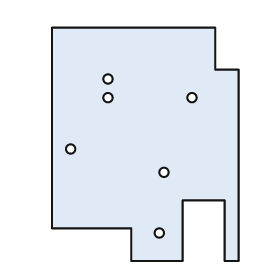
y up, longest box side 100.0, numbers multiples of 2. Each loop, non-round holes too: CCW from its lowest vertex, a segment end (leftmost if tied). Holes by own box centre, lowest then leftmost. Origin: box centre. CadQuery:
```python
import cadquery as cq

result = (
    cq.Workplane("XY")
    .moveTo(-6.0, -50.0)
    .lineTo(16.0, -50.0)
    .lineTo(16.0, -24.0)
    .lineTo(34.0, -24.0)
    .lineTo(34.0, -50.0)
    .lineTo(40.0, -50.0)
    .lineTo(40.0, 32.0)
    .lineTo(30.0, 32.0)
    .lineTo(30.0, 50.0)
    .lineTo(-40.0, 50.0)
    .lineTo(-40.0, -36.0)
    .lineTo(-6.0, -36.0)
    .close()
    .moveTo(6.0, -38.0)
    .circle(2.0)
    .moveTo(8.0, -12.0)
    .circle(2.0)
    .moveTo(-32.0, -2.0)
    .circle(2.0)
    .moveTo(-16.0, 20.0)
    .circle(2.0)
    .moveTo(20.0, 20.0)
    .circle(2.0)
    .moveTo(-16.0, 28.0)
    .circle(2.0)
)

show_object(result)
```